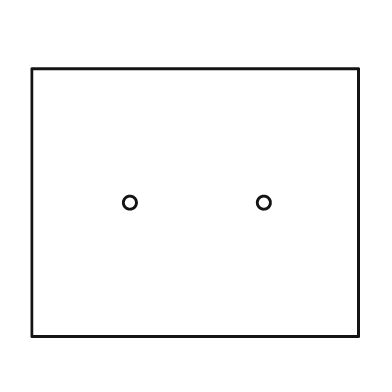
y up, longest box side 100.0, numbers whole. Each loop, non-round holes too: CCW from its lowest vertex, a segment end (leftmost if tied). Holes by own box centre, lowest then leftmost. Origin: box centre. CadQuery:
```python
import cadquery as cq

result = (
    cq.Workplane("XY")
    .moveTo(-50.0, -41.0)
    .lineTo(50.0, -41.0)
    .lineTo(50.0, 41.0)
    .lineTo(-50.0, 41.0)
    .close()
    .moveTo(-20.0, 0.0)
    .circle(2.0)
    .moveTo(21.0, 0.0)
    .circle(2.0)
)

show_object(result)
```